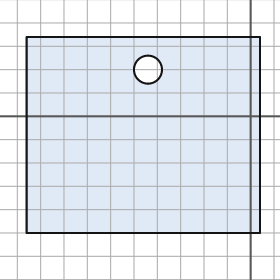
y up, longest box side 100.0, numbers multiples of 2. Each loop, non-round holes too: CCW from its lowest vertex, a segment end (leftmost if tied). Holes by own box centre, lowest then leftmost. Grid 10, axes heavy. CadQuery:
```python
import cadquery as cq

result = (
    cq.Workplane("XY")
    .moveTo(-96.0, -50.0)
    .lineTo(4.0, -50.0)
    .lineTo(4.0, 34.0)
    .lineTo(-96.0, 34.0)
    .close()
    .moveTo(-44.0, 20.0)
    .circle(6.0)
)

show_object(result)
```